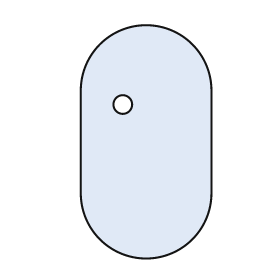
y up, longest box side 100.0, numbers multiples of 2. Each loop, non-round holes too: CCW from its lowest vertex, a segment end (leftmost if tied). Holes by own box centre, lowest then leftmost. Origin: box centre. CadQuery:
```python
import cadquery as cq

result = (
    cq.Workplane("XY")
    .moveTo(-28.0, -22.0)
    .threePointArc((0.0, -50.0), (28.0, -22.0))
    .lineTo(28.0, 22.0)
    .threePointArc((0.0, 50.0), (-28.0, 22.0))
    .close()
    .moveTo(-10.0, 16.0)
    .circle(4.0)
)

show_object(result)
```